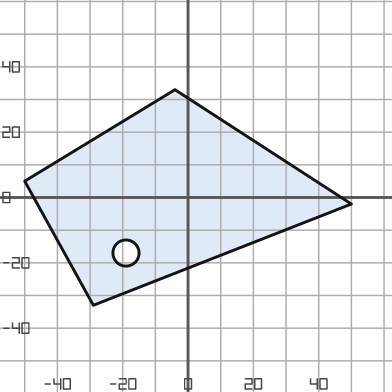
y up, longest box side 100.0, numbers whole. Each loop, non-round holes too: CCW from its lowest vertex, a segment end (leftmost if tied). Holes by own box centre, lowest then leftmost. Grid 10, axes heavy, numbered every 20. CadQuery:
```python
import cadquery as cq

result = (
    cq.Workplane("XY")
    .moveTo(-29.0, -33.0)
    .lineTo(50.0, -2.0)
    .lineTo(-4.0, 33.0)
    .lineTo(-50.0, 5.0)
    .close()
    .moveTo(-19.0, -17.0)
    .circle(4.0)
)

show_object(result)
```